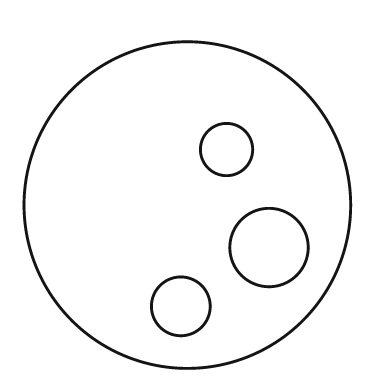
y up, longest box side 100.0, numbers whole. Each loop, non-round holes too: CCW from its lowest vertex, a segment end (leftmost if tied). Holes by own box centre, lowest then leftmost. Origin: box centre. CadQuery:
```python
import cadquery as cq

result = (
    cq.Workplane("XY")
    .moveTo(0.0, 0.0)
    .circle(50.0)
    .moveTo(-2.0, -31.0)
    .circle(9.0)
    .moveTo(25.0, -13.0)
    .circle(12.0)
    .moveTo(12.0, 17.0)
    .circle(8.0)
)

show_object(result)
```